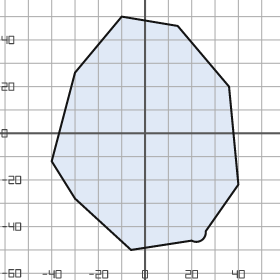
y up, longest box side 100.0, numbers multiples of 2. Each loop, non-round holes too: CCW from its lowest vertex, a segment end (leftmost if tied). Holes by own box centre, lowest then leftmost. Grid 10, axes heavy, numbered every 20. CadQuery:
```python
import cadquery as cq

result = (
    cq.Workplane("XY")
    .moveTo(-6.0, -50.0)
    .lineTo(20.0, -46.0)
    .threePointArc((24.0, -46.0), (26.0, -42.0))
    .lineTo(40.0, -22.0)
    .lineTo(36.0, 20.0)
    .lineTo(14.0, 46.0)
    .lineTo(-10.0, 50.0)
    .lineTo(-30.0, 26.0)
    .lineTo(-40.0, -12.0)
    .lineTo(-30.0, -28.0)
    .close()
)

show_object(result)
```